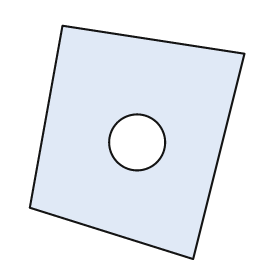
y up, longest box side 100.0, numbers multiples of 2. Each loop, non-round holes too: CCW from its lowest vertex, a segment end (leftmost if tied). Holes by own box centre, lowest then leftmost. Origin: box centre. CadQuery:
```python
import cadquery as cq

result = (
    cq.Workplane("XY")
    .moveTo(24.0, -50.0)
    .lineTo(46.0, 38.0)
    .lineTo(-32.0, 50.0)
    .lineTo(-46.0, -28.0)
    .close()
    .moveTo(0.0, 0.0)
    .circle(12.0)
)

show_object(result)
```